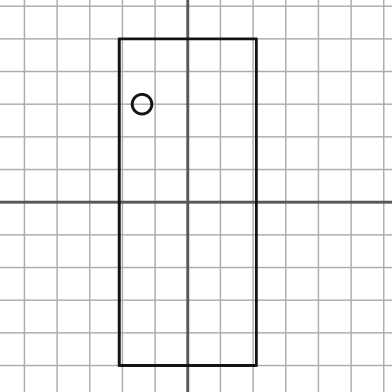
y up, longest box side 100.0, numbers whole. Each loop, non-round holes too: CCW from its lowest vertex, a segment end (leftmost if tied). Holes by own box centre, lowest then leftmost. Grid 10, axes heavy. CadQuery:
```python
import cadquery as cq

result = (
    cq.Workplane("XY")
    .moveTo(-21.0, -50.0)
    .lineTo(21.0, -50.0)
    .lineTo(21.0, 50.0)
    .lineTo(-21.0, 50.0)
    .close()
    .moveTo(-14.0, 30.0)
    .circle(3.0)
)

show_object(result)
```